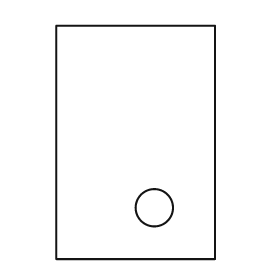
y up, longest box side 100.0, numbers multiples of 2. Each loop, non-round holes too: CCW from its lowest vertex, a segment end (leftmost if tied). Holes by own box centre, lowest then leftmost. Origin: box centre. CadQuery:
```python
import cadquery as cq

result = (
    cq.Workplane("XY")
    .moveTo(-34.0, -50.0)
    .lineTo(34.0, -50.0)
    .lineTo(34.0, 50.0)
    .lineTo(-34.0, 50.0)
    .close()
    .moveTo(8.0, -28.0)
    .circle(8.0)
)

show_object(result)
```